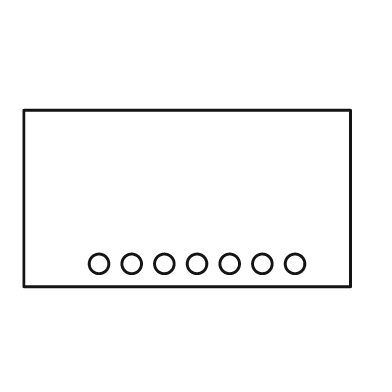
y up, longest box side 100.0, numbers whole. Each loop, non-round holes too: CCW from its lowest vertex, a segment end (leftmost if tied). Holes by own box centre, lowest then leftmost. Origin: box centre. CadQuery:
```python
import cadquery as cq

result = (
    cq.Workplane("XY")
    .moveTo(-50.0, -27.0)
    .lineTo(50.0, -27.0)
    .lineTo(50.0, 27.0)
    .lineTo(-50.0, 27.0)
    .close()
    .moveTo(-27.0, -20.0)
    .circle(3.0)
    .moveTo(-17.0, -20.0)
    .circle(3.0)
    .moveTo(-7.0, -20.0)
    .circle(3.0)
    .moveTo(3.0, -20.0)
    .circle(3.0)
    .moveTo(13.0, -20.0)
    .circle(3.0)
    .moveTo(23.0, -20.0)
    .circle(3.0)
    .moveTo(33.0, -20.0)
    .circle(3.0)
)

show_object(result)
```